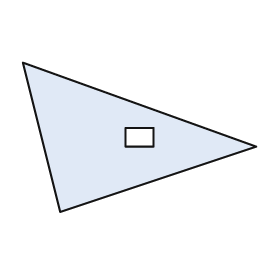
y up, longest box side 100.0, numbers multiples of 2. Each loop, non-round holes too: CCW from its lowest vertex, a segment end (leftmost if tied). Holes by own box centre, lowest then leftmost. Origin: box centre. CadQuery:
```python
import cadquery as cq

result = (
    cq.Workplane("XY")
    .moveTo(-34.0, -32.0)
    .lineTo(50.0, -4.0)
    .lineTo(-50.0, 32.0)
    .close()
    .moveTo(-6.0, -4.0)
    .lineTo(6.0, -4.0)
    .lineTo(6.0, 4.0)
    .lineTo(-6.0, 4.0)
    .close()
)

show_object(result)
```